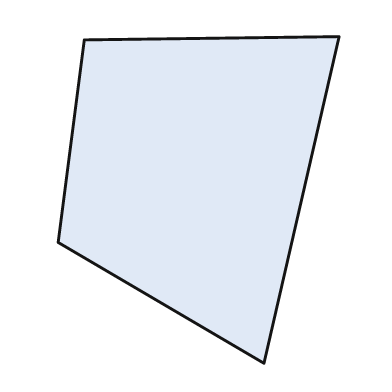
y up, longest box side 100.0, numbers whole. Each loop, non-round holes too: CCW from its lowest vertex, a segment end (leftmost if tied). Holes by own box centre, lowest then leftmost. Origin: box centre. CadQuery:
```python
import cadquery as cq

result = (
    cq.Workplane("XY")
    .moveTo(20.0, -50.0)
    .lineTo(43.0, 50.0)
    .lineTo(-35.0, 49.0)
    .lineTo(-43.0, -13.0)
    .close()
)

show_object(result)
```